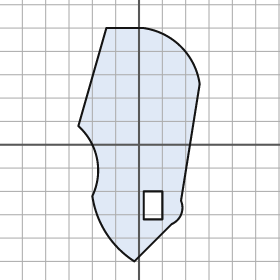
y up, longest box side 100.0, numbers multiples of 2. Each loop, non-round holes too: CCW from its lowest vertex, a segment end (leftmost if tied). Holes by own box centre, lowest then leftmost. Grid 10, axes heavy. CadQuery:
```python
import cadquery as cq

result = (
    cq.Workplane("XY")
    .moveTo(-2.0, -50.0)
    .lineTo(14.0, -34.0)
    .threePointArc((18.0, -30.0), (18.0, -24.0))
    .lineTo(26.0, 26.0)
    .threePointArc((18.0, 42.0), (2.0, 50.0))
    .lineTo(-14.0, 50.0)
    .lineTo(-26.0, 8.0)
    .threePointArc((-18.0, -6.0), (-20.0, -22.0))
    .threePointArc((-14.0, -38.0), (-2.0, -50.0))
    .close()
    .moveTo(2.0, -32.0)
    .lineTo(10.0, -32.0)
    .lineTo(10.0, -20.0)
    .lineTo(2.0, -20.0)
    .close()
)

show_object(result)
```